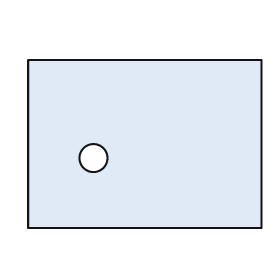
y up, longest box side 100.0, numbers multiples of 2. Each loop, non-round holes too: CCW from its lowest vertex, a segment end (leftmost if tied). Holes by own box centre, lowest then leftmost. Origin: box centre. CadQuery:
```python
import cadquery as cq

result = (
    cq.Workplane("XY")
    .moveTo(-50.0, -36.0)
    .lineTo(50.0, -36.0)
    .lineTo(50.0, 36.0)
    .lineTo(-50.0, 36.0)
    .close()
    .moveTo(-22.0, -6.0)
    .circle(6.0)
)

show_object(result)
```